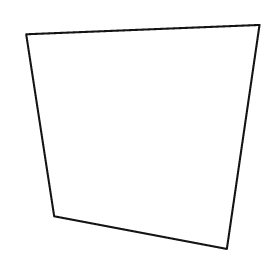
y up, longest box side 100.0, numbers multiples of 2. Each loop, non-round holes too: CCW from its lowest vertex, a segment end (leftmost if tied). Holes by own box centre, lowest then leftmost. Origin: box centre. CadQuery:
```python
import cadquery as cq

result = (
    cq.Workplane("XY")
    .moveTo(36.0, -48.0)
    .lineTo(50.0, 48.0)
    .lineTo(-50.0, 44.0)
    .lineTo(-38.0, -34.0)
    .close()
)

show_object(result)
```